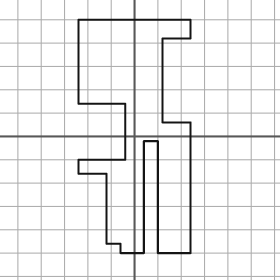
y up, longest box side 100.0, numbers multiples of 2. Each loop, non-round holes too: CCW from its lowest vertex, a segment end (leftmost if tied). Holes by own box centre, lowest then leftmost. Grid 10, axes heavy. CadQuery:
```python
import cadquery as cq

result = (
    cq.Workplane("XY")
    .moveTo(-6.0, -50.0)
    .lineTo(4.0, -50.0)
    .lineTo(4.0, -2.0)
    .lineTo(10.0, -2.0)
    .lineTo(10.0, -50.0)
    .lineTo(24.0, -50.0)
    .lineTo(24.0, 6.0)
    .lineTo(12.0, 6.0)
    .lineTo(12.0, 42.0)
    .lineTo(24.0, 42.0)
    .lineTo(24.0, 50.0)
    .lineTo(-24.0, 50.0)
    .lineTo(-24.0, 14.0)
    .lineTo(-4.0, 14.0)
    .lineTo(-4.0, -10.0)
    .lineTo(-24.0, -10.0)
    .lineTo(-24.0, -16.0)
    .lineTo(-12.0, -16.0)
    .lineTo(-12.0, -46.0)
    .lineTo(-6.0, -46.0)
    .close()
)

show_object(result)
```